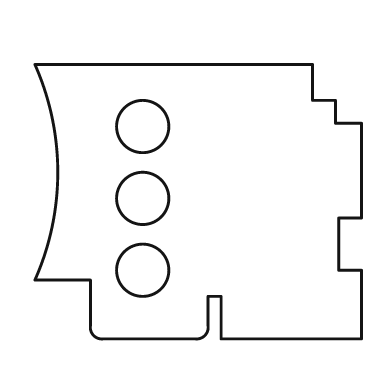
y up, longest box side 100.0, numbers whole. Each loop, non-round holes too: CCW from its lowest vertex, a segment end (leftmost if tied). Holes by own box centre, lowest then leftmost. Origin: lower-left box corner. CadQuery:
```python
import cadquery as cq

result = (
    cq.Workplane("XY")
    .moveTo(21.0, 0.0)
    .lineTo(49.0, 0.0)
    .threePointArc((52.0, 1.0), (53.0, 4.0))
    .lineTo(53.0, 13.0)
    .lineTo(57.0, 13.0)
    .lineTo(57.0, 0.0)
    .lineTo(100.0, 0.0)
    .lineTo(100.0, 21.0)
    .lineTo(93.0, 21.0)
    .lineTo(93.0, 37.0)
    .lineTo(100.0, 37.0)
    .lineTo(100.0, 66.0)
    .lineTo(92.0, 66.0)
    .lineTo(92.0, 73.0)
    .lineTo(85.0, 73.0)
    .lineTo(85.0, 84.0)
    .lineTo(0.0, 84.0)
    .threePointArc((7.0, 51.0), (0.0, 18.0))
    .lineTo(17.0, 18.0)
    .lineTo(17.0, 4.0)
    .threePointArc((18.0, 1.0), (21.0, 0.0))
    .close()
    .moveTo(33.0, 21.0)
    .circle(8.0)
    .moveTo(33.0, 43.0)
    .circle(8.0)
    .moveTo(33.0, 65.0)
    .circle(8.0)
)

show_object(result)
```